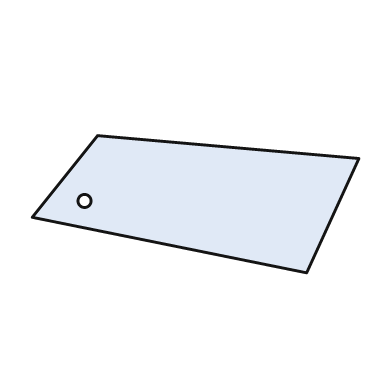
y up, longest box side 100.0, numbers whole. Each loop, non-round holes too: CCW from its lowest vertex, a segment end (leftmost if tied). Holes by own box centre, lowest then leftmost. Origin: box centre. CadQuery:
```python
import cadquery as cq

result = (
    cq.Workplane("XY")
    .moveTo(34.0, -21.0)
    .lineTo(50.0, 14.0)
    .lineTo(-30.0, 21.0)
    .lineTo(-50.0, -4.0)
    .close()
    .moveTo(-34.0, 1.0)
    .circle(2.0)
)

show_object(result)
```